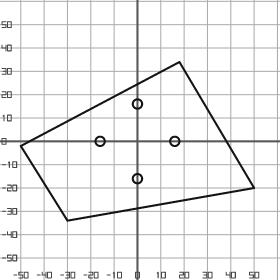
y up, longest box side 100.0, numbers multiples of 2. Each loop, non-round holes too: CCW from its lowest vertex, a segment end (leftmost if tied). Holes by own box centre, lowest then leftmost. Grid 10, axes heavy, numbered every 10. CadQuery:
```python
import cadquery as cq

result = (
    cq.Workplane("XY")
    .moveTo(-30.0, -34.0)
    .lineTo(50.0, -20.0)
    .lineTo(18.0, 34.0)
    .lineTo(-50.0, -2.0)
    .close()
    .moveTo(0.0, -16.0)
    .circle(2.0)
    .moveTo(-16.0, 0.0)
    .circle(2.0)
    .moveTo(16.0, 0.0)
    .circle(2.0)
    .moveTo(0.0, 16.0)
    .circle(2.0)
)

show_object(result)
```